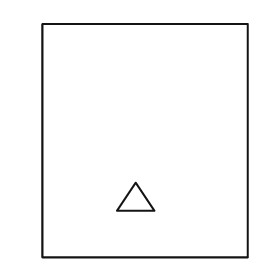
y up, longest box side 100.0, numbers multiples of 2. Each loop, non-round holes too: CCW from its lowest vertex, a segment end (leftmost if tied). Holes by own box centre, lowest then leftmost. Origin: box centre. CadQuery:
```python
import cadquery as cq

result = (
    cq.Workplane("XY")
    .moveTo(-44.0, -50.0)
    .lineTo(44.0, -50.0)
    .lineTo(44.0, 50.0)
    .lineTo(-44.0, 50.0)
    .close()
    .moveTo(-12.0, -30.0)
    .lineTo(4.0, -30.0)
    .lineTo(-4.0, -18.0)
    .close()
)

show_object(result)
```